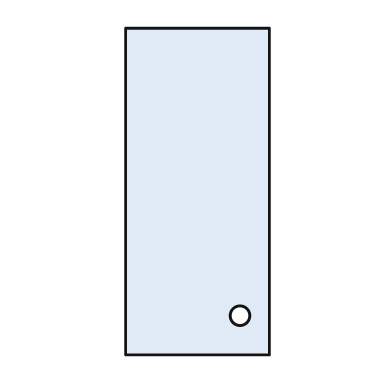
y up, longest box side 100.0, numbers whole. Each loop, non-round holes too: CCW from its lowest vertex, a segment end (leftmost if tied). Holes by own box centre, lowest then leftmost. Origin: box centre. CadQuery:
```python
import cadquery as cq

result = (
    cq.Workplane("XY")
    .moveTo(-22.0, -50.0)
    .lineTo(22.0, -50.0)
    .lineTo(22.0, 50.0)
    .lineTo(-22.0, 50.0)
    .close()
    .moveTo(13.0, -38.0)
    .circle(3.0)
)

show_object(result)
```